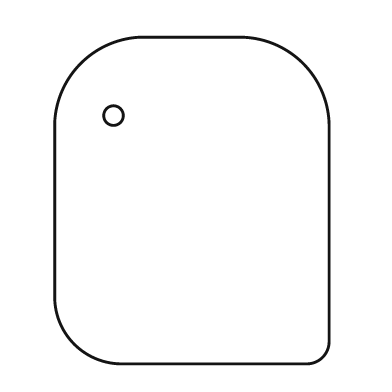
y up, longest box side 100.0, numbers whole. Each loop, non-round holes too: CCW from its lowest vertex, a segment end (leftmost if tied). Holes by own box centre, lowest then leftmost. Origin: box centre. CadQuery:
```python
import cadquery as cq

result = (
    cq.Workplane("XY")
    .moveTo(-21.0, -50.0)
    .lineTo(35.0, -50.0)
    .threePointArc((40.0, -48.0), (42.0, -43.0))
    .lineTo(42.0, 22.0)
    .threePointArc((34.0, 42.0), (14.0, 50.0))
    .lineTo(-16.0, 50.0)
    .threePointArc((-34.0, 42.0), (-42.0, 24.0))
    .lineTo(-42.0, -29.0)
    .threePointArc((-36.0, -44.0), (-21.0, -50.0))
    .close()
    .moveTo(-24.0, 26.0)
    .circle(3.0)
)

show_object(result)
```